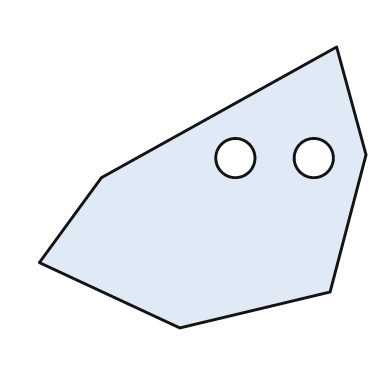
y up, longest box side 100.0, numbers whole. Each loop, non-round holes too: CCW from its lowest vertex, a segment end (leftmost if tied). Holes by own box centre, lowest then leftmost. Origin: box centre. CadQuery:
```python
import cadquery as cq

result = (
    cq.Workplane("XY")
    .moveTo(-7.0, -43.0)
    .lineTo(39.0, -32.0)
    .lineTo(50.0, 10.0)
    .lineTo(41.0, 43.0)
    .lineTo(-31.0, 3.0)
    .lineTo(-50.0, -23.0)
    .close()
    .moveTo(10.0, 9.0)
    .circle(6.0)
    .moveTo(34.0, 9.0)
    .circle(6.0)
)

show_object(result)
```